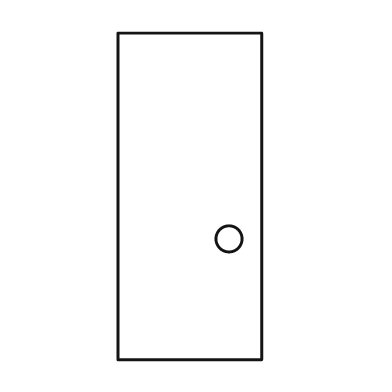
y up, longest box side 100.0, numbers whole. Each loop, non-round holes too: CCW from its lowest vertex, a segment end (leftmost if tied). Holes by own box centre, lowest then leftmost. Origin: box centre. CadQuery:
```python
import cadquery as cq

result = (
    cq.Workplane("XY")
    .moveTo(-22.0, -50.0)
    .lineTo(22.0, -50.0)
    .lineTo(22.0, 50.0)
    .lineTo(-22.0, 50.0)
    .close()
    .moveTo(12.0, -13.0)
    .circle(4.0)
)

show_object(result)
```